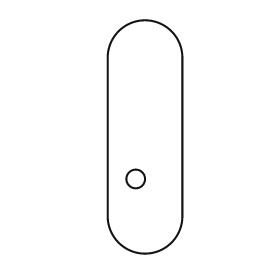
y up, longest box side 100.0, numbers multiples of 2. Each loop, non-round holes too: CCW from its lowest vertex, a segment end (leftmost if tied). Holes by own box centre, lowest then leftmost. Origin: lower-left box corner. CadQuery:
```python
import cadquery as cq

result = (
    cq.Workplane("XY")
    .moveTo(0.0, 16.0)
    .threePointArc((16.0, 0.0), (32.0, 16.0))
    .lineTo(32.0, 84.0)
    .threePointArc((16.0, 100.0), (0.0, 84.0))
    .close()
    .moveTo(12.0, 32.0)
    .circle(4.0)
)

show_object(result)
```